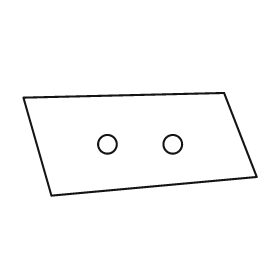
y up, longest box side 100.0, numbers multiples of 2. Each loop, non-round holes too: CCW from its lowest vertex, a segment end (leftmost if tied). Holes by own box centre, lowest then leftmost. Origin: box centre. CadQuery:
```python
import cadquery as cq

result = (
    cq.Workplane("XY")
    .moveTo(-38.0, -22.0)
    .lineTo(50.0, -14.0)
    .lineTo(36.0, 22.0)
    .lineTo(-50.0, 20.0)
    .close()
    .moveTo(-14.0, 0.0)
    .circle(4.0)
    .moveTo(14.0, 0.0)
    .circle(4.0)
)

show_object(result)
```